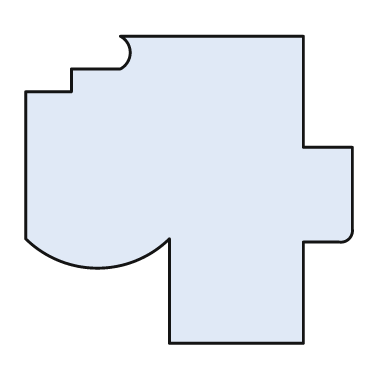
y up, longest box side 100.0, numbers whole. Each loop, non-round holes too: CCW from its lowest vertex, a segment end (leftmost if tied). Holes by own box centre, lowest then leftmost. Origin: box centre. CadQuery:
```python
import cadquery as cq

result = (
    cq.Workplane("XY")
    .moveTo(-6.0, -47.0)
    .lineTo(35.0, -47.0)
    .lineTo(35.0, -16.0)
    .lineTo(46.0, -16.0)
    .threePointArc((49.0, -15.0), (50.0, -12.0))
    .lineTo(50.0, 13.0)
    .lineTo(35.0, 13.0)
    .lineTo(35.0, 47.0)
    .lineTo(-21.0, 47.0)
    .threePointArc((-18.0, 42.0), (-21.0, 37.0))
    .lineTo(-36.0, 37.0)
    .lineTo(-36.0, 30.0)
    .lineTo(-50.0, 30.0)
    .lineTo(-50.0, -15.0)
    .threePointArc((-28.0, -24.0), (-6.0, -15.0))
    .close()
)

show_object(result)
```